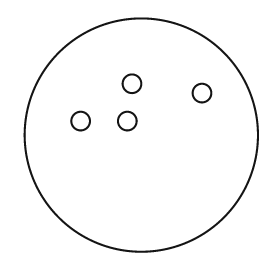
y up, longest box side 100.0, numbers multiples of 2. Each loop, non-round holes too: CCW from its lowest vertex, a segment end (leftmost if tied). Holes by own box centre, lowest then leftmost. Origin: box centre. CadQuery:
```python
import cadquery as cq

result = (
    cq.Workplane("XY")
    .moveTo(0.0, 0.0)
    .circle(50.0)
    .moveTo(-26.0, 6.0)
    .circle(4.0)
    .moveTo(-6.0, 6.0)
    .circle(4.0)
    .moveTo(26.0, 18.0)
    .circle(4.0)
    .moveTo(-4.0, 22.0)
    .circle(4.0)
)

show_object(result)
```